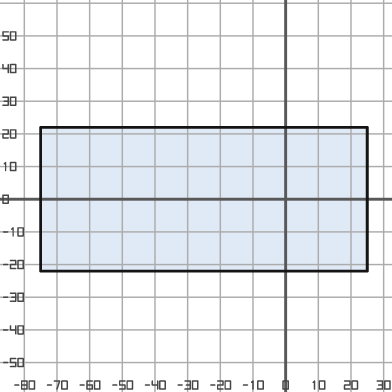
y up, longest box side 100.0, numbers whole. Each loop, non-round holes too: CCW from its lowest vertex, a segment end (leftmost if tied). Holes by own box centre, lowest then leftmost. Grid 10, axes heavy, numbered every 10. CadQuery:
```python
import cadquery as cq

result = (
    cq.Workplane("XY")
    .moveTo(-75.0, -22.0)
    .lineTo(25.0, -22.0)
    .lineTo(25.0, 22.0)
    .lineTo(-75.0, 22.0)
    .close()
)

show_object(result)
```